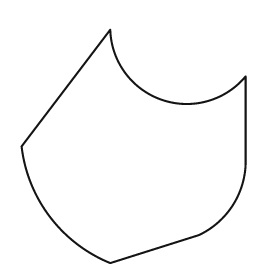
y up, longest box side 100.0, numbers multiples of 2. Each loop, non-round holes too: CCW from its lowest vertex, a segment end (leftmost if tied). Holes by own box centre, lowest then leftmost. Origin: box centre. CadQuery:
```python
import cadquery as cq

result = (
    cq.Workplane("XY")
    .moveTo(-10.0, -50.0)
    .lineTo(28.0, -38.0)
    .threePointArc((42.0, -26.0), (48.0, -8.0))
    .lineTo(48.0, 30.0)
    .threePointArc((12.0, 20.0), (-10.0, 50.0))
    .lineTo(-48.0, 0.0)
    .threePointArc((-36.0, -30.0), (-10.0, -50.0))
    .close()
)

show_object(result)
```